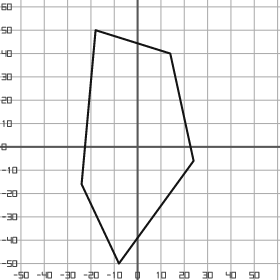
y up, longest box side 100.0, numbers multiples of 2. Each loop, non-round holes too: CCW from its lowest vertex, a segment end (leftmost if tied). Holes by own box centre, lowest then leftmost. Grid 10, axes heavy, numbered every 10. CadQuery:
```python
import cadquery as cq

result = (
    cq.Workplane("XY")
    .moveTo(-8.0, -50.0)
    .lineTo(24.0, -6.0)
    .lineTo(14.0, 40.0)
    .lineTo(-18.0, 50.0)
    .lineTo(-24.0, -16.0)
    .close()
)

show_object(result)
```